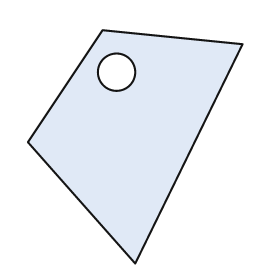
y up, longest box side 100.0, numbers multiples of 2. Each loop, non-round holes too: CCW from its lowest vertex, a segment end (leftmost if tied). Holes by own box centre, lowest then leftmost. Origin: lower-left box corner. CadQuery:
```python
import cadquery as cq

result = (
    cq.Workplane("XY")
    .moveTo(46.0, 0.0)
    .lineTo(92.0, 94.0)
    .lineTo(32.0, 100.0)
    .lineTo(0.0, 52.0)
    .close()
    .moveTo(38.0, 82.0)
    .circle(8.0)
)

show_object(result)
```